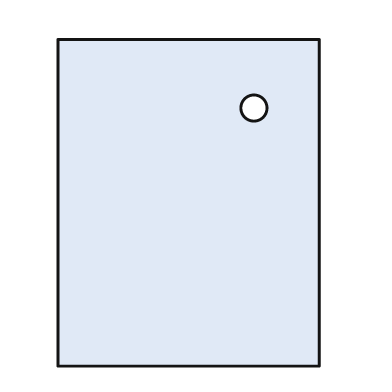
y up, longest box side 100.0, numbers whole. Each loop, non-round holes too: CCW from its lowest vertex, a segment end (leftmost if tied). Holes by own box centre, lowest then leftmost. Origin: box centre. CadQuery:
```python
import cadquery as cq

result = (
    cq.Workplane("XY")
    .moveTo(-40.0, -50.0)
    .lineTo(40.0, -50.0)
    .lineTo(40.0, 50.0)
    .lineTo(-40.0, 50.0)
    .close()
    .moveTo(20.0, 29.0)
    .circle(4.0)
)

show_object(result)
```